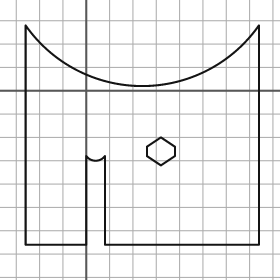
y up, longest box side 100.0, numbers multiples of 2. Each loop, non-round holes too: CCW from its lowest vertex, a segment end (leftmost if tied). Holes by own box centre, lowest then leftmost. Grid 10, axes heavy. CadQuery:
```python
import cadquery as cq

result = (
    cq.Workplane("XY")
    .moveTo(-26.0, -66.0)
    .lineTo(0.0, -66.0)
    .lineTo(0.0, -28.0)
    .threePointArc((4.0, -30.0), (8.0, -28.0))
    .lineTo(8.0, -66.0)
    .lineTo(74.0, -66.0)
    .lineTo(74.0, 28.0)
    .threePointArc((24.0, 2.0), (-26.0, 28.0))
    .close()
    .moveTo(32.0, -32.0)
    .lineTo(38.0, -28.0)
    .lineTo(38.0, -24.0)
    .lineTo(32.0, -20.0)
    .lineTo(26.0, -24.0)
    .lineTo(26.0, -28.0)
    .close()
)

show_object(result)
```